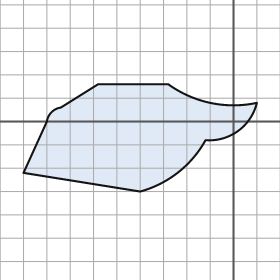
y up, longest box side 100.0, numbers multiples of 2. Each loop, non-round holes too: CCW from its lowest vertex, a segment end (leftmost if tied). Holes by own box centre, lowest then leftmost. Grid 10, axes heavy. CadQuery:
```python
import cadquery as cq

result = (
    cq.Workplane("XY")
    .moveTo(-40.0, -30.0)
    .threePointArc((-24.0, -22.0), (-12.0, -8.0))
    .threePointArc((2.0, -4.0), (10.0, 8.0))
    .threePointArc((-10.0, 8.0), (-28.0, 16.0))
    .lineTo(-58.0, 16.0)
    .lineTo(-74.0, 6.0)
    .threePointArc((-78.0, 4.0), (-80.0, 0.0))
    .lineTo(-90.0, -22.0)
    .close()
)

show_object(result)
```